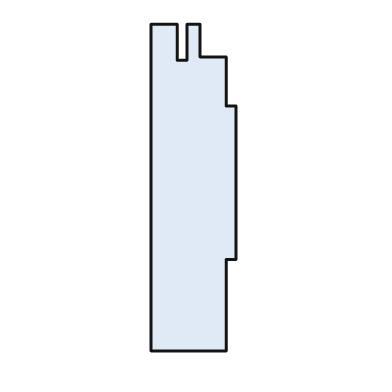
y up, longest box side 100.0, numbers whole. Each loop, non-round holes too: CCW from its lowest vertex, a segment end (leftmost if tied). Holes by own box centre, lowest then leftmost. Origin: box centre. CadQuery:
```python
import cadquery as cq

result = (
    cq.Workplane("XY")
    .moveTo(-13.0, -50.0)
    .lineTo(10.0, -50.0)
    .lineTo(10.0, -22.0)
    .lineTo(13.0, -22.0)
    .lineTo(13.0, 25.0)
    .lineTo(10.0, 25.0)
    .lineTo(10.0, 40.0)
    .lineTo(2.0, 40.0)
    .lineTo(2.0, 50.0)
    .lineTo(-2.0, 50.0)
    .lineTo(-2.0, 39.0)
    .lineTo(-5.0, 39.0)
    .lineTo(-5.0, 50.0)
    .lineTo(-13.0, 50.0)
    .close()
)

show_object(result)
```